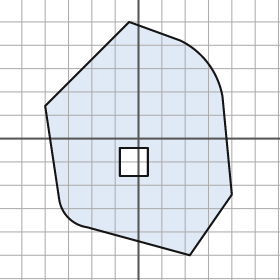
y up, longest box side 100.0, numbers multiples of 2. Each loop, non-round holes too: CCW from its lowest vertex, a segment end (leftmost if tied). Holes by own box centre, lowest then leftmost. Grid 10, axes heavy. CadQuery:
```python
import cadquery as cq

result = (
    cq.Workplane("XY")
    .moveTo(22.0, -50.0)
    .lineTo(40.0, -24.0)
    .lineTo(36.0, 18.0)
    .threePointArc((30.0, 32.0), (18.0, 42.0))
    .lineTo(-4.0, 50.0)
    .lineTo(-40.0, 14.0)
    .lineTo(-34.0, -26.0)
    .threePointArc((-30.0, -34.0), (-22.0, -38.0))
    .close()
    .moveTo(-8.0, -16.0)
    .lineTo(4.0, -16.0)
    .lineTo(4.0, -4.0)
    .lineTo(-8.0, -4.0)
    .close()
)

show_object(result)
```